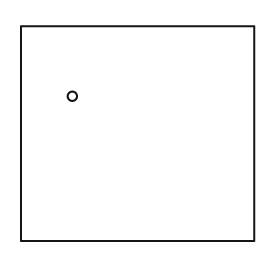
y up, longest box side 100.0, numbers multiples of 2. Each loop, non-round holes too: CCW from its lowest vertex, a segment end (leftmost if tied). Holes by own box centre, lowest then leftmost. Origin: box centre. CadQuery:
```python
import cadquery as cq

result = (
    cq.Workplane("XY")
    .moveTo(-50.0, -46.0)
    .lineTo(50.0, -46.0)
    .lineTo(50.0, 46.0)
    .lineTo(-50.0, 46.0)
    .close()
    .moveTo(-28.0, 16.0)
    .circle(2.0)
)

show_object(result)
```